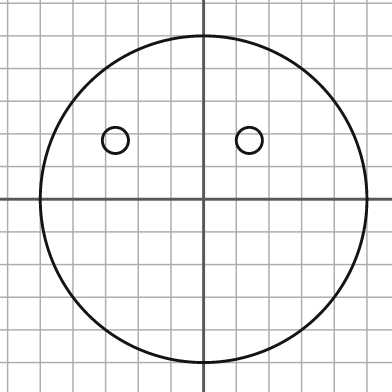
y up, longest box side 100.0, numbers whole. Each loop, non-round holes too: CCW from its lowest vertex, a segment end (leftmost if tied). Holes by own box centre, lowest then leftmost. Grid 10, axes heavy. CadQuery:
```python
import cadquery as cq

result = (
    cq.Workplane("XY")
    .moveTo(0.0, 0.0)
    .circle(50.0)
    .moveTo(-27.0, 18.0)
    .circle(4.0)
    .moveTo(14.0, 18.0)
    .circle(4.0)
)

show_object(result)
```